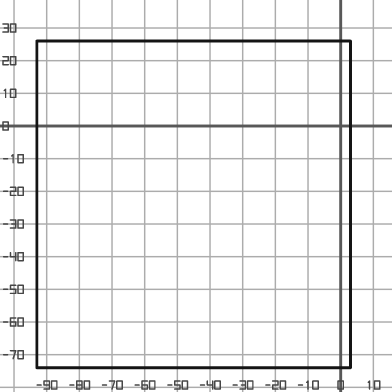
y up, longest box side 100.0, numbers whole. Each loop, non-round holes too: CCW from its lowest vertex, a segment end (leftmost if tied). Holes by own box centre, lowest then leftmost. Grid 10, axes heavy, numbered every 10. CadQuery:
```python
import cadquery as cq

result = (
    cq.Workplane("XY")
    .moveTo(-93.0, -74.0)
    .lineTo(3.0, -74.0)
    .lineTo(3.0, 26.0)
    .lineTo(-93.0, 26.0)
    .close()
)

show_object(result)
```